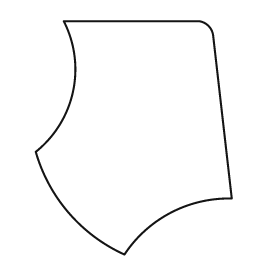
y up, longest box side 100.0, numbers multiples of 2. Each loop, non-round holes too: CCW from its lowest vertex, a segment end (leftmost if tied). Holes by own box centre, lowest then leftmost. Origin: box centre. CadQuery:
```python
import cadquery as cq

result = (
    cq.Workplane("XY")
    .moveTo(-4.0, -50.0)
    .threePointArc((16.0, -32.0), (42.0, -26.0))
    .lineTo(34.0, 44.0)
    .threePointArc((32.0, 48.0), (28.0, 50.0))
    .lineTo(-30.0, 50.0)
    .threePointArc((-26.0, 20.0), (-42.0, -6.0))
    .threePointArc((-28.0, -32.0), (-4.0, -50.0))
    .close()
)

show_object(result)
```